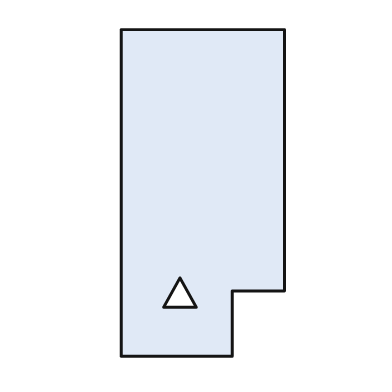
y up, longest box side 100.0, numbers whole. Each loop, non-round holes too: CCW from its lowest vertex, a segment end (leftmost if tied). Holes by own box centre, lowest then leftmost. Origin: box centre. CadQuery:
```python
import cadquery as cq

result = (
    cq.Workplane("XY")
    .moveTo(-25.0, -50.0)
    .lineTo(9.0, -50.0)
    .lineTo(9.0, -30.0)
    .lineTo(25.0, -30.0)
    .lineTo(25.0, 50.0)
    .lineTo(-25.0, 50.0)
    .close()
    .moveTo(-12.0, -35.0)
    .lineTo(-2.0, -35.0)
    .lineTo(-7.0, -26.0)
    .close()
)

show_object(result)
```